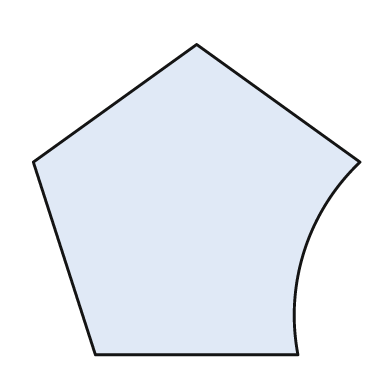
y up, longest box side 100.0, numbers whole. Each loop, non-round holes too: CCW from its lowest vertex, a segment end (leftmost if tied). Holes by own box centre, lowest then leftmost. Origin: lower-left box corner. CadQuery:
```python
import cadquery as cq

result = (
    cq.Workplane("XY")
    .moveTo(19.0, 0.0)
    .lineTo(81.0, 0.0)
    .threePointArc((83.0, 32.0), (100.0, 59.0))
    .lineTo(50.0, 95.0)
    .lineTo(0.0, 59.0)
    .close()
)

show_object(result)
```